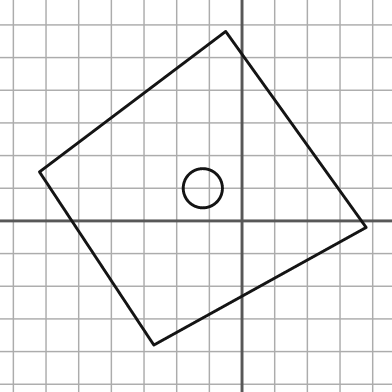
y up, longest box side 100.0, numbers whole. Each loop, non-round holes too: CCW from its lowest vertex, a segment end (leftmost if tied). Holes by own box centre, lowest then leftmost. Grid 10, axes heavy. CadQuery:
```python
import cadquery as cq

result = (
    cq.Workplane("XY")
    .moveTo(-27.0, -38.0)
    .lineTo(38.0, -2.0)
    .lineTo(-5.0, 58.0)
    .lineTo(-62.0, 15.0)
    .close()
    .moveTo(-12.0, 10.0)
    .circle(6.0)
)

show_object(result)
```